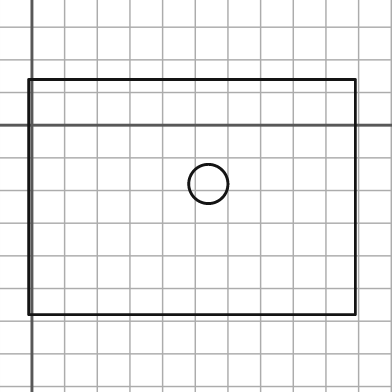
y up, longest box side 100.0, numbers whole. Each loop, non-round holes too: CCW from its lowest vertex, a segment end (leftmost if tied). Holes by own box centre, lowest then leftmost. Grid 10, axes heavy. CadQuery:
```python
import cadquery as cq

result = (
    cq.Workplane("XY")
    .moveTo(-1.0, -58.0)
    .lineTo(99.0, -58.0)
    .lineTo(99.0, 14.0)
    .lineTo(-1.0, 14.0)
    .close()
    .moveTo(54.0, -18.0)
    .circle(6.0)
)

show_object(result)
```